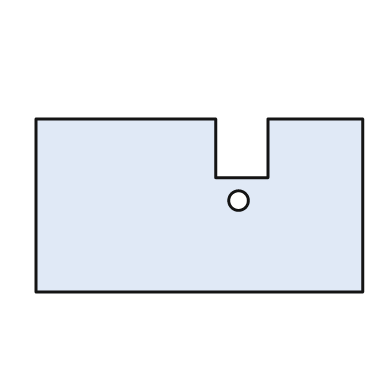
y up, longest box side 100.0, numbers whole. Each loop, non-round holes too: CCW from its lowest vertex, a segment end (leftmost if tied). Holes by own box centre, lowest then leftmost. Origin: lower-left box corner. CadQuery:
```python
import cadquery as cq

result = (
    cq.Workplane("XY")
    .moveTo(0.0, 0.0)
    .lineTo(100.0, 0.0)
    .lineTo(100.0, 53.0)
    .lineTo(71.0, 53.0)
    .lineTo(71.0, 35.0)
    .lineTo(55.0, 35.0)
    .lineTo(55.0, 53.0)
    .lineTo(0.0, 53.0)
    .close()
    .moveTo(62.0, 28.0)
    .circle(3.0)
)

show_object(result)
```